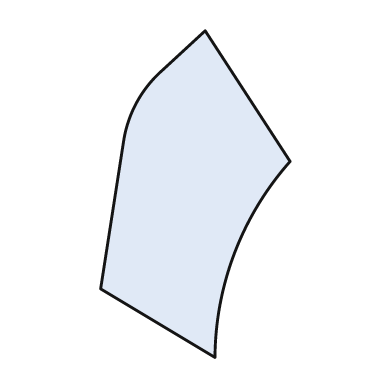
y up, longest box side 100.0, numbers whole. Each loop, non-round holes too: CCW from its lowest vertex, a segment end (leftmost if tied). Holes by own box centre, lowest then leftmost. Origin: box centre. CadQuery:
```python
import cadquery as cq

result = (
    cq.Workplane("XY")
    .moveTo(6.0, -50.0)
    .threePointArc((12.0, -18.0), (29.0, 10.0))
    .lineTo(3.0, 50.0)
    .lineTo(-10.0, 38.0)
    .threePointArc((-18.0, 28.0), (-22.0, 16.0))
    .lineTo(-29.0, -29.0)
    .close()
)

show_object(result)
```